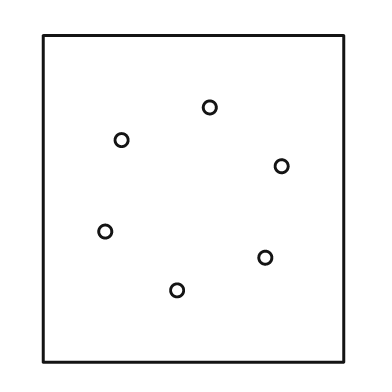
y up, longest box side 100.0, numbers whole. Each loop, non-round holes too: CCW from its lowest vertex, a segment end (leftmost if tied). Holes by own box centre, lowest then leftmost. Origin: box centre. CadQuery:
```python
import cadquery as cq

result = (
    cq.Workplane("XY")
    .moveTo(-46.0, -50.0)
    .lineTo(46.0, -50.0)
    .lineTo(46.0, 50.0)
    .lineTo(-46.0, 50.0)
    .close()
    .moveTo(-5.0, -28.0)
    .circle(2.0)
    .moveTo(22.0, -18.0)
    .circle(2.0)
    .moveTo(-27.0, -10.0)
    .circle(2.0)
    .moveTo(27.0, 10.0)
    .circle(2.0)
    .moveTo(-22.0, 18.0)
    .circle(2.0)
    .moveTo(5.0, 28.0)
    .circle(2.0)
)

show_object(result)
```